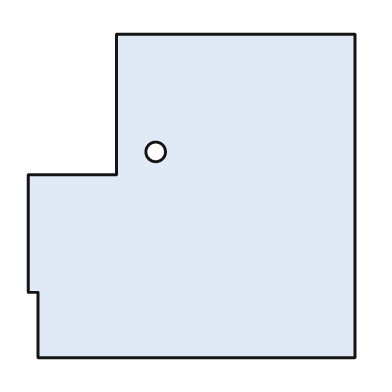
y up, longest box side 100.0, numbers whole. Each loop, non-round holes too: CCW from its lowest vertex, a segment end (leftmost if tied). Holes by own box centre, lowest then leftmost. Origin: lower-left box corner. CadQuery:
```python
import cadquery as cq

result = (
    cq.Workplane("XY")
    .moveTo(3.0, 0.0)
    .lineTo(100.0, 0.0)
    .lineTo(100.0, 99.0)
    .lineTo(27.0, 99.0)
    .lineTo(27.0, 56.0)
    .lineTo(0.0, 56.0)
    .lineTo(0.0, 20.0)
    .lineTo(3.0, 20.0)
    .close()
    .moveTo(39.0, 63.0)
    .circle(3.0)
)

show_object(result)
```